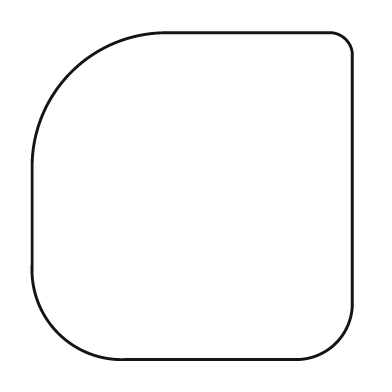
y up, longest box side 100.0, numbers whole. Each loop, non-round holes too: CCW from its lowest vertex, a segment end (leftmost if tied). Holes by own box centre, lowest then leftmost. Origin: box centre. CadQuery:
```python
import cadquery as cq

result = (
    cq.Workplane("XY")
    .moveTo(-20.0, -50.0)
    .lineTo(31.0, -50.0)
    .threePointArc((44.0, -45.0), (49.0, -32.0))
    .lineTo(49.0, 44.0)
    .threePointArc((47.0, 48.0), (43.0, 50.0))
    .lineTo(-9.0, 50.0)
    .threePointArc((-37.0, 38.0), (-49.0, 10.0))
    .lineTo(-49.0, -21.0)
    .threePointArc((-41.0, -42.0), (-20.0, -50.0))
    .close()
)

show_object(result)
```